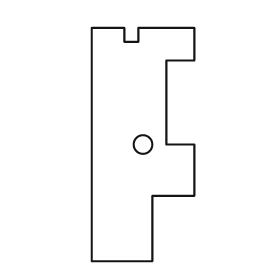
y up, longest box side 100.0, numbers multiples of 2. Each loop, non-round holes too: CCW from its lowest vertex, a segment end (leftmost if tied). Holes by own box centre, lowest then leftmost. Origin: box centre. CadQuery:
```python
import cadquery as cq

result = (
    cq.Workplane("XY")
    .moveTo(-22.0, -50.0)
    .lineTo(4.0, -50.0)
    .lineTo(4.0, -22.0)
    .lineTo(22.0, -22.0)
    .lineTo(22.0, 0.0)
    .lineTo(10.0, 0.0)
    .lineTo(10.0, 36.0)
    .lineTo(22.0, 36.0)
    .lineTo(22.0, 50.0)
    .lineTo(-2.0, 50.0)
    .lineTo(-2.0, 44.0)
    .lineTo(-8.0, 44.0)
    .lineTo(-8.0, 50.0)
    .lineTo(-22.0, 50.0)
    .close()
    .moveTo(0.0, 0.0)
    .circle(4.0)
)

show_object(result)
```